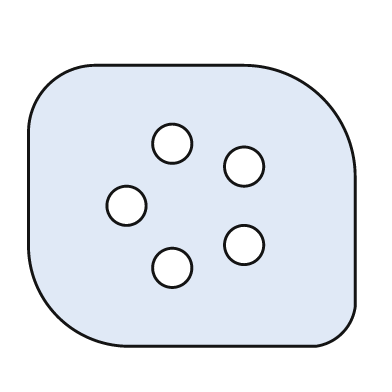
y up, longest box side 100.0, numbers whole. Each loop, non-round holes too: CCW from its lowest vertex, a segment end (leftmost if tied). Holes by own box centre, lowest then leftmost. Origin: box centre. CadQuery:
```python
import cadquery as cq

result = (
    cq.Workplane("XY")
    .moveTo(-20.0, -43.0)
    .lineTo(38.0, -43.0)
    .threePointArc((46.0, -39.0), (50.0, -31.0))
    .lineTo(50.0, 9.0)
    .threePointArc((40.0, 33.0), (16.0, 43.0))
    .lineTo(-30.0, 43.0)
    .threePointArc((-44.0, 37.0), (-50.0, 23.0))
    .lineTo(-50.0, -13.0)
    .threePointArc((-41.0, -34.0), (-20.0, -43.0))
    .close()
    .moveTo(-6.0, -19.0)
    .circle(6.0)
    .moveTo(16.0, -12.0)
    .circle(6.0)
    .moveTo(-20.0, 0.0)
    .circle(6.0)
    .moveTo(16.0, 12.0)
    .circle(6.0)
    .moveTo(-6.0, 19.0)
    .circle(6.0)
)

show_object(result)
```